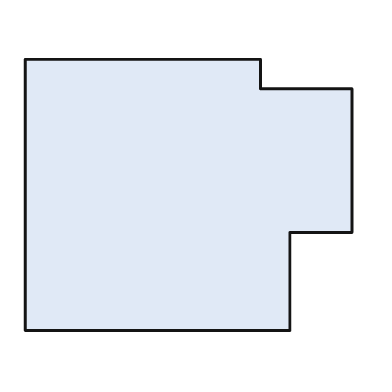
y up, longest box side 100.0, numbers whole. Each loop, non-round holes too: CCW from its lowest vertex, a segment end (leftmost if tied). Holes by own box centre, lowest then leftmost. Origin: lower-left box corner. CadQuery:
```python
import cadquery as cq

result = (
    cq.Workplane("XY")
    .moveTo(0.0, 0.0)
    .lineTo(81.0, 0.0)
    .lineTo(81.0, 30.0)
    .lineTo(100.0, 30.0)
    .lineTo(100.0, 74.0)
    .lineTo(72.0, 74.0)
    .lineTo(72.0, 83.0)
    .lineTo(0.0, 83.0)
    .close()
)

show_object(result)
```